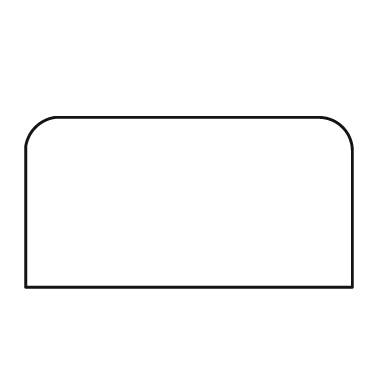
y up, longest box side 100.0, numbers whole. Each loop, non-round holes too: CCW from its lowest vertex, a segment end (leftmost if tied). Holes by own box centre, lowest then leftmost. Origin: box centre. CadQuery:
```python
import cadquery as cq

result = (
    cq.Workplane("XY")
    .moveTo(-50.0, -26.0)
    .lineTo(50.0, -26.0)
    .lineTo(50.0, 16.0)
    .threePointArc((47.0, 23.0), (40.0, 26.0))
    .lineTo(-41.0, 26.0)
    .threePointArc((-47.0, 23.0), (-50.0, 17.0))
    .close()
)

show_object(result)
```